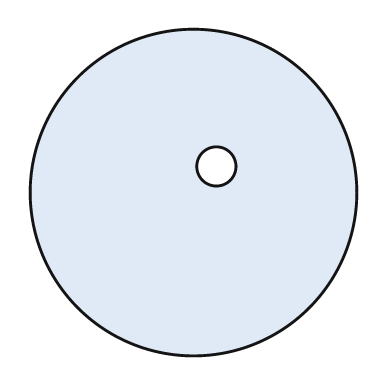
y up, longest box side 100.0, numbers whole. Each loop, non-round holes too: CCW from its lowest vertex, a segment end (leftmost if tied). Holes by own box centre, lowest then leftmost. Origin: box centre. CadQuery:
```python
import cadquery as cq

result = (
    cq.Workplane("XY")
    .moveTo(0.0, 0.0)
    .circle(50.0)
    .moveTo(7.0, 8.0)
    .circle(6.0)
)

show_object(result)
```